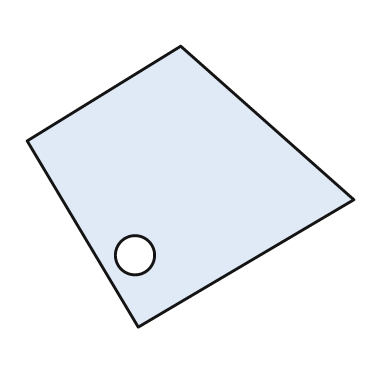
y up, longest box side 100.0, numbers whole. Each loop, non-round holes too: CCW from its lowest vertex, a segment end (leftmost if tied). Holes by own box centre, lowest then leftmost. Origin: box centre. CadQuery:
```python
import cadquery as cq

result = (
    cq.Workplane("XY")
    .moveTo(-16.0, -43.0)
    .lineTo(50.0, -4.0)
    .lineTo(-3.0, 43.0)
    .lineTo(-50.0, 14.0)
    .close()
    .moveTo(-17.0, -21.0)
    .circle(6.0)
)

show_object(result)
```